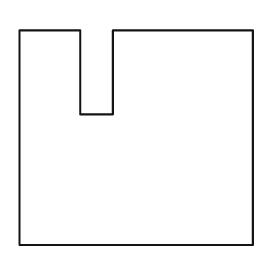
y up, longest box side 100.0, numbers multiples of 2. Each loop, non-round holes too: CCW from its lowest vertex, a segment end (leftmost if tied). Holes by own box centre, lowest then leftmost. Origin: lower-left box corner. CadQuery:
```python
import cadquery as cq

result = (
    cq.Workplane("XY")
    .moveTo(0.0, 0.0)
    .lineTo(100.0, 0.0)
    .lineTo(100.0, 92.0)
    .lineTo(40.0, 92.0)
    .lineTo(40.0, 56.0)
    .lineTo(26.0, 56.0)
    .lineTo(26.0, 92.0)
    .lineTo(0.0, 92.0)
    .close()
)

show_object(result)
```